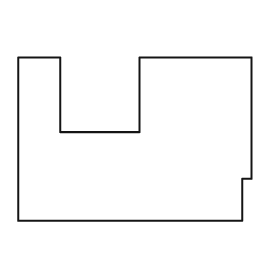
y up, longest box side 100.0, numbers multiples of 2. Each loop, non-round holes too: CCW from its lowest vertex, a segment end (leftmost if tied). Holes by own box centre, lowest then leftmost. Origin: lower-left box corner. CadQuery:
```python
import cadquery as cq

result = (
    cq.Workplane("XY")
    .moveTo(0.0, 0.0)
    .lineTo(96.0, 0.0)
    .lineTo(96.0, 18.0)
    .lineTo(100.0, 18.0)
    .lineTo(100.0, 70.0)
    .lineTo(52.0, 70.0)
    .lineTo(52.0, 38.0)
    .lineTo(18.0, 38.0)
    .lineTo(18.0, 70.0)
    .lineTo(0.0, 70.0)
    .close()
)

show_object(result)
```